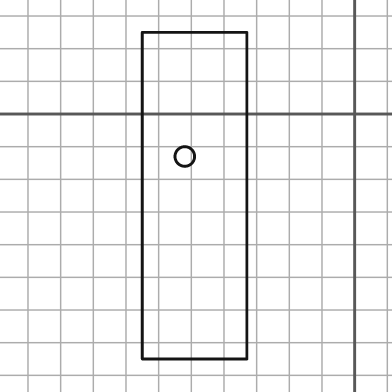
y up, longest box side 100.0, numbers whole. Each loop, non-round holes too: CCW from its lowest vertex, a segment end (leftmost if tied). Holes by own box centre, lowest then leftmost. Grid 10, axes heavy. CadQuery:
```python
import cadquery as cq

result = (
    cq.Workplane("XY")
    .moveTo(-65.0, -75.0)
    .lineTo(-33.0, -75.0)
    .lineTo(-33.0, 25.0)
    .lineTo(-65.0, 25.0)
    .close()
    .moveTo(-52.0, -13.0)
    .circle(3.0)
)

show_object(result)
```